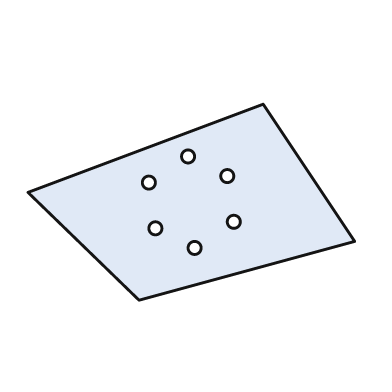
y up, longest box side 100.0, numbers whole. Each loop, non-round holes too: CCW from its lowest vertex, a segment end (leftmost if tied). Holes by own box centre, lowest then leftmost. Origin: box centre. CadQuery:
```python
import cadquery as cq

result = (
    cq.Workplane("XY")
    .moveTo(-16.0, -30.0)
    .lineTo(50.0, -12.0)
    .lineTo(22.0, 30.0)
    .lineTo(-50.0, 3.0)
    .close()
    .moveTo(1.0, -14.0)
    .circle(2.0)
    .moveTo(-11.0, -8.0)
    .circle(2.0)
    .moveTo(13.0, -6.0)
    .circle(2.0)
    .moveTo(-13.0, 6.0)
    .circle(2.0)
    .moveTo(11.0, 8.0)
    .circle(2.0)
    .moveTo(-1.0, 14.0)
    .circle(2.0)
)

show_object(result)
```